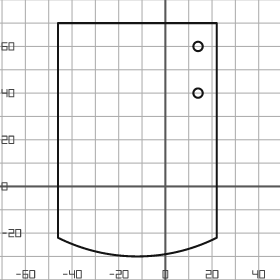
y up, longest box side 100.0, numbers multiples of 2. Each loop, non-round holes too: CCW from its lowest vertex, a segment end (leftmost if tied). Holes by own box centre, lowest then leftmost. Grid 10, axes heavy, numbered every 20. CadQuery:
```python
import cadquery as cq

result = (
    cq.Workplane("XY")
    .moveTo(-46.0, -22.0)
    .threePointArc((-12.0, -30.0), (22.0, -22.0))
    .lineTo(22.0, 70.0)
    .lineTo(-46.0, 70.0)
    .close()
    .moveTo(14.0, 40.0)
    .circle(2.0)
    .moveTo(14.0, 60.0)
    .circle(2.0)
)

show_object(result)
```